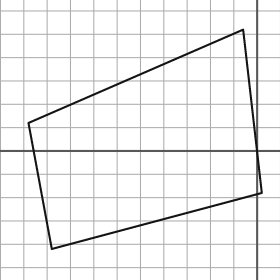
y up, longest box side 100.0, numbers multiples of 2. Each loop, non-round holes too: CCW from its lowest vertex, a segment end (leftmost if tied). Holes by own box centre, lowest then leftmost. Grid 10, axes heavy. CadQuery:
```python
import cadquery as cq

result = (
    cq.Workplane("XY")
    .moveTo(-88.0, -42.0)
    .lineTo(2.0, -18.0)
    .lineTo(-6.0, 52.0)
    .lineTo(-98.0, 12.0)
    .close()
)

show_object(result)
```